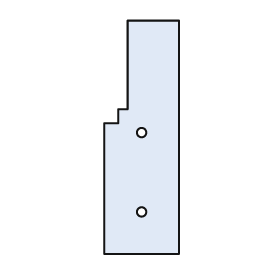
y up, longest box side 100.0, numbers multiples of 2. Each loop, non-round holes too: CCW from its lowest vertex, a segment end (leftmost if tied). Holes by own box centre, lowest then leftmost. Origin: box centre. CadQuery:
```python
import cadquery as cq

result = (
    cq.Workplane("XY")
    .moveTo(-16.0, -50.0)
    .lineTo(16.0, -50.0)
    .lineTo(16.0, 50.0)
    .lineTo(-6.0, 50.0)
    .lineTo(-6.0, 12.0)
    .lineTo(-10.0, 12.0)
    .lineTo(-10.0, 6.0)
    .lineTo(-16.0, 6.0)
    .close()
    .moveTo(0.0, -32.0)
    .circle(2.0)
    .moveTo(0.0, 2.0)
    .circle(2.0)
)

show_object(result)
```